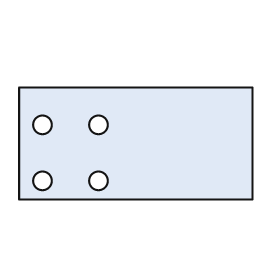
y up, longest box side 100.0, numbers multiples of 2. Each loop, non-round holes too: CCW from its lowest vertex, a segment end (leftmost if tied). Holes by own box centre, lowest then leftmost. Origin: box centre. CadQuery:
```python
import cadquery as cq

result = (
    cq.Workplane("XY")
    .moveTo(-50.0, -24.0)
    .lineTo(50.0, -24.0)
    .lineTo(50.0, 24.0)
    .lineTo(-50.0, 24.0)
    .close()
    .moveTo(-40.0, -16.0)
    .circle(4.0)
    .moveTo(-16.0, -16.0)
    .circle(4.0)
    .moveTo(-40.0, 8.0)
    .circle(4.0)
    .moveTo(-16.0, 8.0)
    .circle(4.0)
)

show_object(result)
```